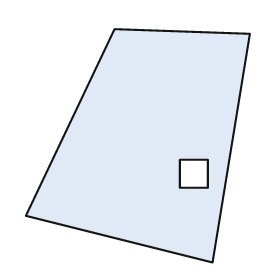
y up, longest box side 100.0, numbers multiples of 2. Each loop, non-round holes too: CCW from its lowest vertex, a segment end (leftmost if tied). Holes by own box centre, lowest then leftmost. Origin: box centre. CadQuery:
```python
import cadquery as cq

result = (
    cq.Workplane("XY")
    .moveTo(32.0, -50.0)
    .lineTo(48.0, 48.0)
    .lineTo(-10.0, 50.0)
    .lineTo(-48.0, -30.0)
    .close()
    .moveTo(18.0, -18.0)
    .lineTo(30.0, -18.0)
    .lineTo(30.0, -6.0)
    .lineTo(18.0, -6.0)
    .close()
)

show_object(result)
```